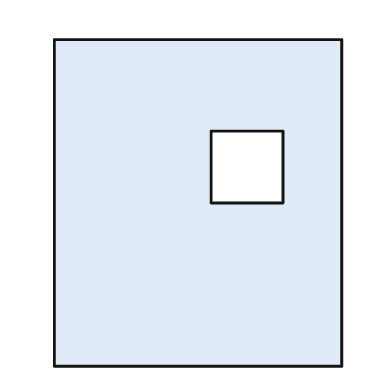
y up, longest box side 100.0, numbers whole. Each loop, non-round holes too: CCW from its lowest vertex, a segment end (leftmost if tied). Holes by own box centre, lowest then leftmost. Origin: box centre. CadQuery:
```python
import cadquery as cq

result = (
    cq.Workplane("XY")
    .moveTo(-44.0, -50.0)
    .lineTo(44.0, -50.0)
    .lineTo(44.0, 50.0)
    .lineTo(-44.0, 50.0)
    .close()
    .moveTo(4.0, 0.0)
    .lineTo(26.0, 0.0)
    .lineTo(26.0, 22.0)
    .lineTo(4.0, 22.0)
    .close()
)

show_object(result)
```